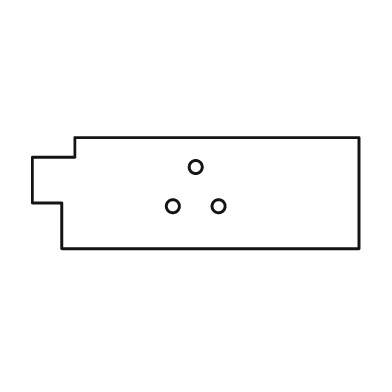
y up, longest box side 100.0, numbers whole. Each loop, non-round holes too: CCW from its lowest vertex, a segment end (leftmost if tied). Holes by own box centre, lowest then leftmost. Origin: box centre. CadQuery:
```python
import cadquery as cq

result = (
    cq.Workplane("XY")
    .moveTo(-41.0, -17.0)
    .lineTo(50.0, -17.0)
    .lineTo(50.0, 17.0)
    .lineTo(-37.0, 17.0)
    .lineTo(-37.0, 11.0)
    .lineTo(-50.0, 11.0)
    .lineTo(-50.0, -3.0)
    .lineTo(-41.0, -3.0)
    .close()
    .moveTo(-7.0, -4.0)
    .circle(2.0)
    .moveTo(7.0, -4.0)
    .circle(2.0)
    .moveTo(0.0, 8.0)
    .circle(2.0)
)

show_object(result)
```